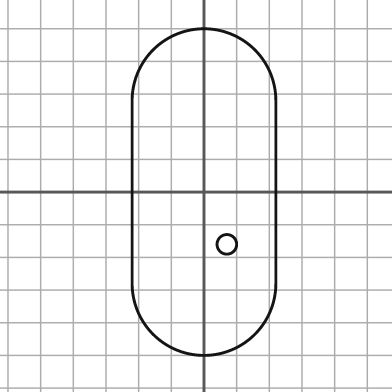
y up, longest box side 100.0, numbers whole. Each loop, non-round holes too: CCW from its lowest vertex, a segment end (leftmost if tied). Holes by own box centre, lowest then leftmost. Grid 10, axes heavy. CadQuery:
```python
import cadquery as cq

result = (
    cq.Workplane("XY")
    .moveTo(-22.0, -28.0)
    .threePointArc((0.0, -50.0), (22.0, -28.0))
    .lineTo(22.0, 28.0)
    .threePointArc((0.0, 50.0), (-22.0, 28.0))
    .close()
    .moveTo(7.0, -16.0)
    .circle(3.0)
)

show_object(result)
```